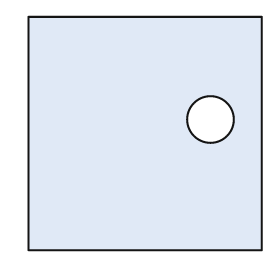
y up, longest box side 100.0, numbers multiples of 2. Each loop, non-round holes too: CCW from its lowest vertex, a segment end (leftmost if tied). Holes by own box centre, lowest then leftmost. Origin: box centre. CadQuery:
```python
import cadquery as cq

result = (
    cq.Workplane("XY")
    .moveTo(-50.0, -50.0)
    .lineTo(50.0, -50.0)
    .lineTo(50.0, 50.0)
    .lineTo(-50.0, 50.0)
    .close()
    .moveTo(28.0, 6.0)
    .circle(10.0)
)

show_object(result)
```